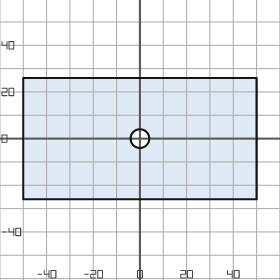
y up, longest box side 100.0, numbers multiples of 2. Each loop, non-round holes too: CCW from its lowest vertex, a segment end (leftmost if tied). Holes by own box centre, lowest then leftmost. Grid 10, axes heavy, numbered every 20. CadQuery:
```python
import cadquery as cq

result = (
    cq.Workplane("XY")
    .moveTo(-50.0, -26.0)
    .lineTo(50.0, -26.0)
    .lineTo(50.0, 26.0)
    .lineTo(-50.0, 26.0)
    .close()
    .moveTo(0.0, 0.0)
    .circle(4.0)
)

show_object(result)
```